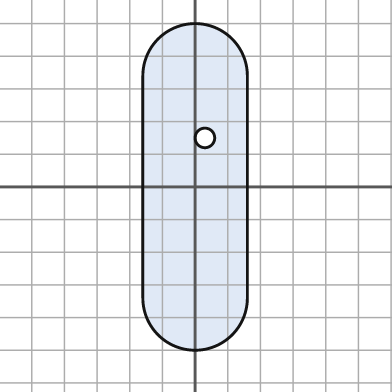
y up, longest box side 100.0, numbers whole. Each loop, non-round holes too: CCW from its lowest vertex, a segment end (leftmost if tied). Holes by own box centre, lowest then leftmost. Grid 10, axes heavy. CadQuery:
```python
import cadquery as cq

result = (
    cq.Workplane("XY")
    .moveTo(-16.0, -34.0)
    .threePointArc((0.0, -50.0), (16.0, -34.0))
    .lineTo(16.0, 34.0)
    .threePointArc((0.0, 50.0), (-16.0, 34.0))
    .close()
    .moveTo(3.0, 15.0)
    .circle(3.0)
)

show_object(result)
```